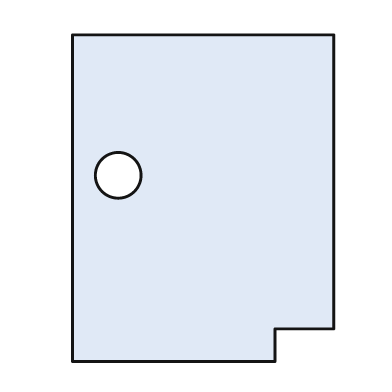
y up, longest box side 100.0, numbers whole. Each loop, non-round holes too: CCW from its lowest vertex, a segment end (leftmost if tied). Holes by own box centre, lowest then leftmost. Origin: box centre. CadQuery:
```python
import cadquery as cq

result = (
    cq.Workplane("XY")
    .moveTo(-40.0, -50.0)
    .lineTo(22.0, -50.0)
    .lineTo(22.0, -40.0)
    .lineTo(40.0, -40.0)
    .lineTo(40.0, 50.0)
    .lineTo(-40.0, 50.0)
    .close()
    .moveTo(-26.0, 7.0)
    .circle(7.0)
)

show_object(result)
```